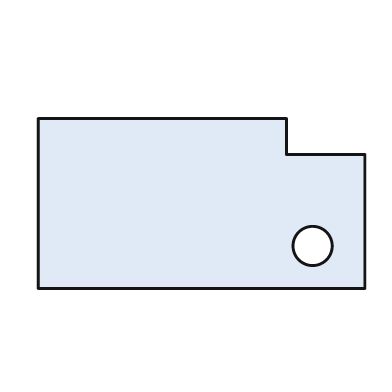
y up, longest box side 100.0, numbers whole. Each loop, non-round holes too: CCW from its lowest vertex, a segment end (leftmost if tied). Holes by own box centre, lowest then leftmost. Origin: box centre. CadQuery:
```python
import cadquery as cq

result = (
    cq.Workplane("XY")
    .moveTo(-50.0, -26.0)
    .lineTo(50.0, -26.0)
    .lineTo(50.0, 15.0)
    .lineTo(26.0, 15.0)
    .lineTo(26.0, 26.0)
    .lineTo(-50.0, 26.0)
    .close()
    .moveTo(34.0, -13.0)
    .circle(6.0)
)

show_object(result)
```